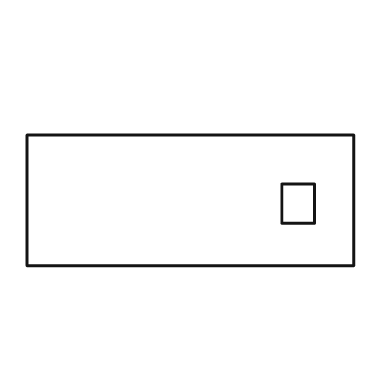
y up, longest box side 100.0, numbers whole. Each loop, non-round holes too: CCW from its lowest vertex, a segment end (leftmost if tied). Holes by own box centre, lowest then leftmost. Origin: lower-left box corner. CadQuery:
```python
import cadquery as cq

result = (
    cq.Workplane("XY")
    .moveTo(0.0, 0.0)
    .lineTo(100.0, 0.0)
    .lineTo(100.0, 40.0)
    .lineTo(0.0, 40.0)
    .close()
    .moveTo(78.0, 13.0)
    .lineTo(88.0, 13.0)
    .lineTo(88.0, 25.0)
    .lineTo(78.0, 25.0)
    .close()
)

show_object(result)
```